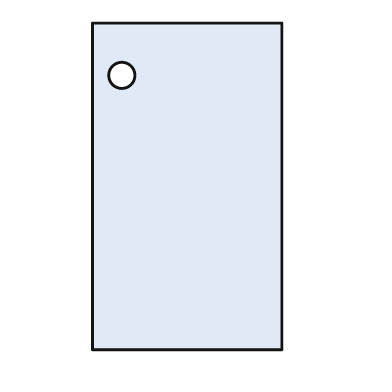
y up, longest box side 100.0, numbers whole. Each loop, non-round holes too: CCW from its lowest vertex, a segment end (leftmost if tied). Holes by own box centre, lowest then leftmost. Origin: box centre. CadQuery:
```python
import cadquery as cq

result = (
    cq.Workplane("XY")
    .moveTo(-29.0, -50.0)
    .lineTo(29.0, -50.0)
    .lineTo(29.0, 50.0)
    .lineTo(-29.0, 50.0)
    .close()
    .moveTo(-20.0, 34.0)
    .circle(4.0)
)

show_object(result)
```